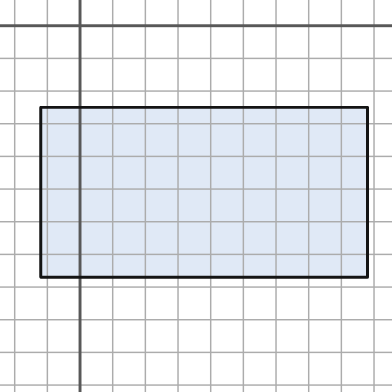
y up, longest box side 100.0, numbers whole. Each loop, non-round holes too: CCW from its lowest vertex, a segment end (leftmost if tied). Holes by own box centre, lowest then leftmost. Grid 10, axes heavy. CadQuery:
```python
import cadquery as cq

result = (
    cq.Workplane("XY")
    .moveTo(-12.0, -77.0)
    .lineTo(88.0, -77.0)
    .lineTo(88.0, -25.0)
    .lineTo(-12.0, -25.0)
    .close()
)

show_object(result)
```